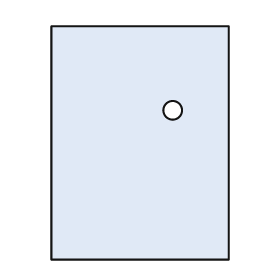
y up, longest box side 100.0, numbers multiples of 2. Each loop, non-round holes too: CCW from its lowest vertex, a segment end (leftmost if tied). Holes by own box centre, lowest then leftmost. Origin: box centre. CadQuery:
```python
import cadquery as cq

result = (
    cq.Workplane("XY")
    .moveTo(-38.0, -50.0)
    .lineTo(38.0, -50.0)
    .lineTo(38.0, 50.0)
    .lineTo(-38.0, 50.0)
    .close()
    .moveTo(14.0, 14.0)
    .circle(4.0)
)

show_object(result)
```